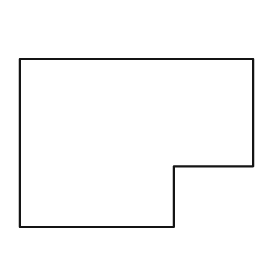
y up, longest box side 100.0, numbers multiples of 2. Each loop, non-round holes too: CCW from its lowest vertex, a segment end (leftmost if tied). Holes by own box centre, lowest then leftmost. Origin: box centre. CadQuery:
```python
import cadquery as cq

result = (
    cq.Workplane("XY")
    .moveTo(-50.0, -36.0)
    .lineTo(16.0, -36.0)
    .lineTo(16.0, -10.0)
    .lineTo(50.0, -10.0)
    .lineTo(50.0, 36.0)
    .lineTo(-50.0, 36.0)
    .close()
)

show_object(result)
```